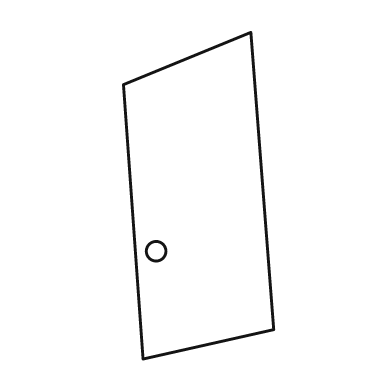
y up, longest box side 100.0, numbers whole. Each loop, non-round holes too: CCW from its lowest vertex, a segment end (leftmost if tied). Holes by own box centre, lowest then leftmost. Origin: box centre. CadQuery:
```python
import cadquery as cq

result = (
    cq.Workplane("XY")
    .moveTo(-17.0, -50.0)
    .lineTo(23.0, -41.0)
    .lineTo(16.0, 50.0)
    .lineTo(-23.0, 34.0)
    .close()
    .moveTo(-13.0, -17.0)
    .circle(3.0)
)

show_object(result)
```